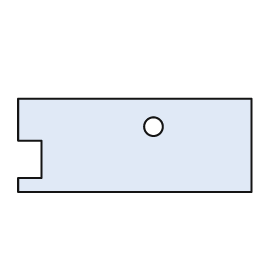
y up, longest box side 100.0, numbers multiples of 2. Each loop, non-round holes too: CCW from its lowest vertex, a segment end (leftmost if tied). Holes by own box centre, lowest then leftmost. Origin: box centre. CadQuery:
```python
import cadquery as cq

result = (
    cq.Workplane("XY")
    .moveTo(-50.0, -20.0)
    .lineTo(50.0, -20.0)
    .lineTo(50.0, 20.0)
    .lineTo(-50.0, 20.0)
    .lineTo(-50.0, 2.0)
    .lineTo(-40.0, 2.0)
    .lineTo(-40.0, -14.0)
    .lineTo(-50.0, -14.0)
    .close()
    .moveTo(8.0, 8.0)
    .circle(4.0)
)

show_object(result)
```